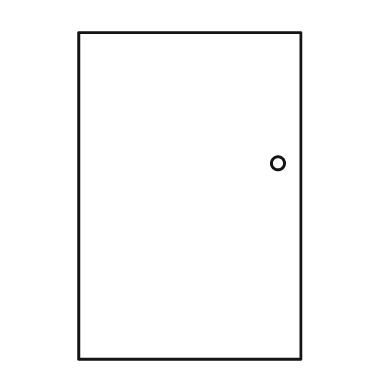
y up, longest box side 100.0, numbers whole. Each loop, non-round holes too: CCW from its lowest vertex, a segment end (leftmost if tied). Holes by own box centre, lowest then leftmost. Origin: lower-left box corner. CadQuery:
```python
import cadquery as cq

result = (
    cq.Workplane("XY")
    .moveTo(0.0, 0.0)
    .lineTo(68.0, 0.0)
    .lineTo(68.0, 100.0)
    .lineTo(0.0, 100.0)
    .close()
    .moveTo(61.0, 60.0)
    .circle(2.0)
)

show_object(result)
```